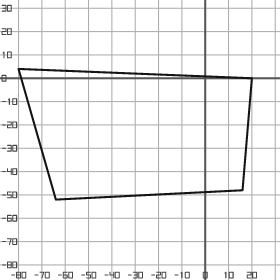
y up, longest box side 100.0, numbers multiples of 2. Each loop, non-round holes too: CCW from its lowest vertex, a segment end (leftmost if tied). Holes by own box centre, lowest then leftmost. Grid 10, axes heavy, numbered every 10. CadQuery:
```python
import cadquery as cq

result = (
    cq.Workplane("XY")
    .moveTo(-64.0, -52.0)
    .lineTo(16.0, -48.0)
    .lineTo(20.0, 0.0)
    .lineTo(-80.0, 4.0)
    .close()
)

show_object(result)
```